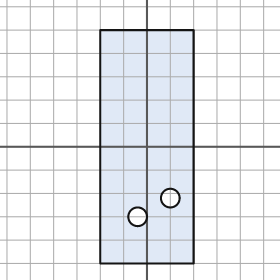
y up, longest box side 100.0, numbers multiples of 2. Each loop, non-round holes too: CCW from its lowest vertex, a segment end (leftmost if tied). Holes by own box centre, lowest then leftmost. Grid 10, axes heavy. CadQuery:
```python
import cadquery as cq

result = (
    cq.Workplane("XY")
    .moveTo(-20.0, -50.0)
    .lineTo(20.0, -50.0)
    .lineTo(20.0, 50.0)
    .lineTo(-20.0, 50.0)
    .close()
    .moveTo(-4.0, -30.0)
    .circle(4.0)
    .moveTo(10.0, -22.0)
    .circle(4.0)
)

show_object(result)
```